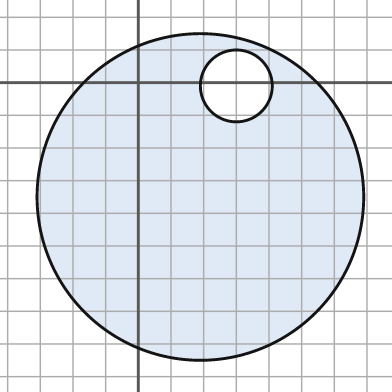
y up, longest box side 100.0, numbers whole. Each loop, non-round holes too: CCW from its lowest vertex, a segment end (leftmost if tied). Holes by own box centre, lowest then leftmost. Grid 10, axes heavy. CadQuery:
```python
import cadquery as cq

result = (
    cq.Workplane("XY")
    .moveTo(19.0, -35.0)
    .circle(50.0)
    .moveTo(30.0, -1.0)
    .circle(11.0)
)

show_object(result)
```